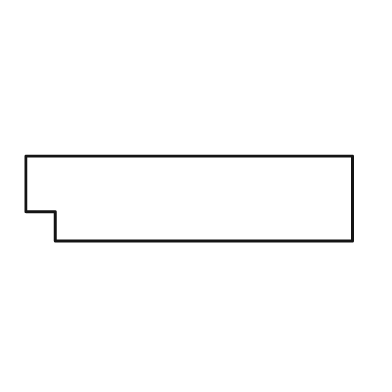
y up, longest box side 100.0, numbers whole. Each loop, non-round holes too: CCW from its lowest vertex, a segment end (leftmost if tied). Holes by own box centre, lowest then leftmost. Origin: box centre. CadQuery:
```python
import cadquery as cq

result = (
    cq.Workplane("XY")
    .moveTo(-41.0, -13.0)
    .lineTo(50.0, -13.0)
    .lineTo(50.0, 13.0)
    .lineTo(-50.0, 13.0)
    .lineTo(-50.0, -4.0)
    .lineTo(-41.0, -4.0)
    .close()
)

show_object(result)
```